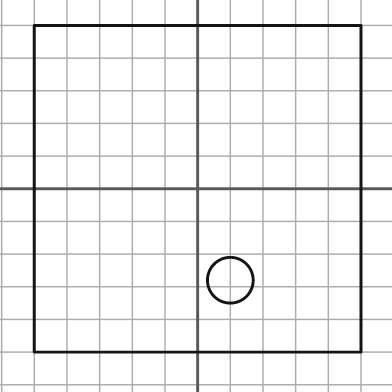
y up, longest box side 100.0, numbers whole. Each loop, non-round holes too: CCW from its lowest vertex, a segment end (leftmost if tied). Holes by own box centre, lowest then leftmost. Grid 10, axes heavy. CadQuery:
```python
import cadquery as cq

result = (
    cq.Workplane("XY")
    .moveTo(-50.0, -50.0)
    .lineTo(50.0, -50.0)
    .lineTo(50.0, 50.0)
    .lineTo(-50.0, 50.0)
    .close()
    .moveTo(10.0, -28.0)
    .circle(7.0)
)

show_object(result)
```